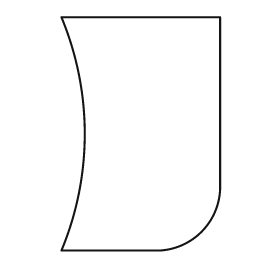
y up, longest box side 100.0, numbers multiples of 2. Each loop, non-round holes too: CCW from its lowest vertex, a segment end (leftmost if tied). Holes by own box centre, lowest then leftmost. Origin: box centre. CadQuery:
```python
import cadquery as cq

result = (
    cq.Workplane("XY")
    .moveTo(-34.0, -50.0)
    .lineTo(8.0, -50.0)
    .threePointArc((26.0, -42.0), (34.0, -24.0))
    .lineTo(34.0, 50.0)
    .lineTo(-34.0, 50.0)
    .threePointArc((-24.0, 0.0), (-34.0, -50.0))
    .close()
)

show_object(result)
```